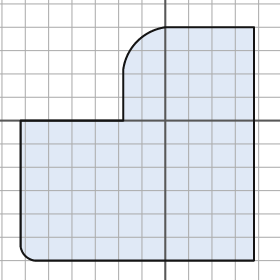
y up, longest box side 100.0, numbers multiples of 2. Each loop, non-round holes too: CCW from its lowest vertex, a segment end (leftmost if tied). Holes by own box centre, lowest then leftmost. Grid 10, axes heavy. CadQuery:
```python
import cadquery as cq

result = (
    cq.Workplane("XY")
    .moveTo(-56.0, -60.0)
    .lineTo(38.0, -60.0)
    .lineTo(38.0, 40.0)
    .lineTo(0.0, 40.0)
    .threePointArc((-12.0, 34.0), (-18.0, 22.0))
    .lineTo(-18.0, 0.0)
    .lineTo(-62.0, 0.0)
    .lineTo(-62.0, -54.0)
    .threePointArc((-60.0, -58.0), (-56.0, -60.0))
    .close()
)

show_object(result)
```